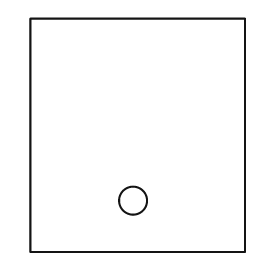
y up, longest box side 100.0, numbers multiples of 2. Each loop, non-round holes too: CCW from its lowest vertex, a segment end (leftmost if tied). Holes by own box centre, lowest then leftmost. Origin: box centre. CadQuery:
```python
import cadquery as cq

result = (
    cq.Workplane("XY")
    .moveTo(-46.0, -50.0)
    .lineTo(46.0, -50.0)
    .lineTo(46.0, 50.0)
    .lineTo(-46.0, 50.0)
    .close()
    .moveTo(-2.0, -28.0)
    .circle(6.0)
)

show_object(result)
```